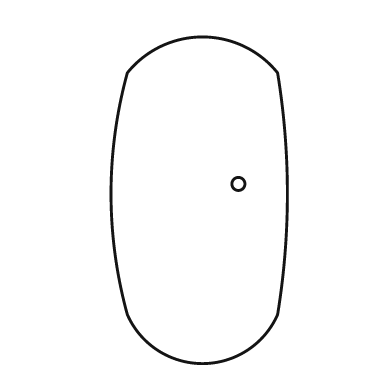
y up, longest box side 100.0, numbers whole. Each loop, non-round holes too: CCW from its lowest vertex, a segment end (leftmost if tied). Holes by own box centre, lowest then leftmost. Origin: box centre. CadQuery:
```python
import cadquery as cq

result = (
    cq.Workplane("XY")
    .moveTo(-22.0, -35.0)
    .threePointArc((1.0, -50.0), (24.0, -35.0))
    .threePointArc((27.0, 2.0), (24.0, 39.0))
    .threePointArc((1.0, 50.0), (-22.0, 39.0))
    .threePointArc((-27.0, 2.0), (-22.0, -35.0))
    .close()
    .moveTo(12.0, 5.0)
    .circle(2.0)
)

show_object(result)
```